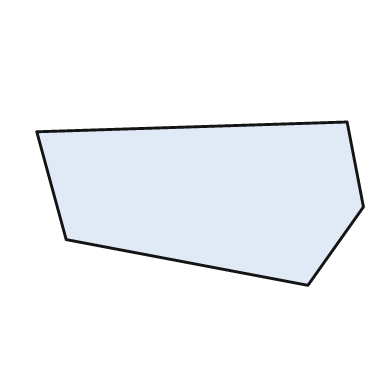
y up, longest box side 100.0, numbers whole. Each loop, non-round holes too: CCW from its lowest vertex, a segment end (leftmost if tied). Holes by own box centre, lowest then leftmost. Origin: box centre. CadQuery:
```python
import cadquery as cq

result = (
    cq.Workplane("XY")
    .moveTo(33.0, -25.0)
    .lineTo(50.0, -1.0)
    .lineTo(45.0, 25.0)
    .lineTo(-50.0, 22.0)
    .lineTo(-41.0, -11.0)
    .close()
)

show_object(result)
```